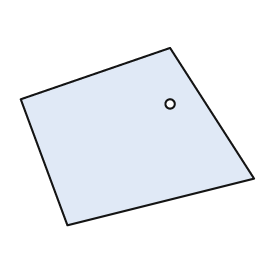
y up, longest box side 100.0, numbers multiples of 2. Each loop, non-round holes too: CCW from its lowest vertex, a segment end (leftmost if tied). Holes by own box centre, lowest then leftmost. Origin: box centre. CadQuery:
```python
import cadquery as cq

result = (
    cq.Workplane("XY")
    .moveTo(-30.0, -38.0)
    .lineTo(50.0, -18.0)
    .lineTo(14.0, 38.0)
    .lineTo(-50.0, 16.0)
    .close()
    .moveTo(14.0, 14.0)
    .circle(2.0)
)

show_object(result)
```